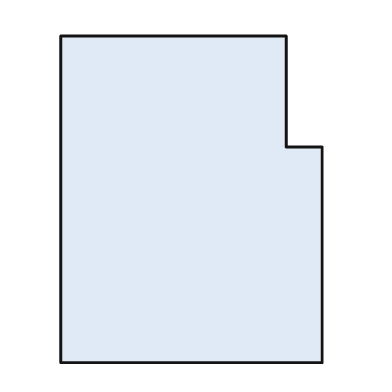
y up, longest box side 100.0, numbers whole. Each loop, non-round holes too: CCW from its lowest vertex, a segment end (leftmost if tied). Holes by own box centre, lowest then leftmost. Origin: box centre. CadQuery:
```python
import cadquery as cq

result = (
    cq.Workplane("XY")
    .moveTo(-40.0, -50.0)
    .lineTo(40.0, -50.0)
    .lineTo(40.0, 16.0)
    .lineTo(29.0, 16.0)
    .lineTo(29.0, 50.0)
    .lineTo(-40.0, 50.0)
    .close()
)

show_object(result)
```